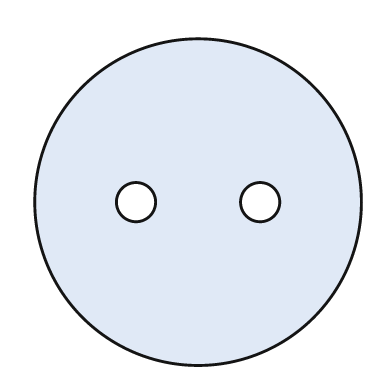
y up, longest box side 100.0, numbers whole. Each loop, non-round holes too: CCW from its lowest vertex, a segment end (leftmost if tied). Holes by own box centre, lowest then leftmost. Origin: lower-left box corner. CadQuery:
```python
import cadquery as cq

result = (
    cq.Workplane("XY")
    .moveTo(50.0, 50.0)
    .circle(50.0)
    .moveTo(31.0, 50.0)
    .circle(6.0)
    .moveTo(69.0, 50.0)
    .circle(6.0)
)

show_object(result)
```